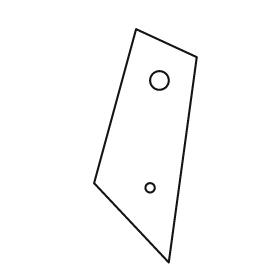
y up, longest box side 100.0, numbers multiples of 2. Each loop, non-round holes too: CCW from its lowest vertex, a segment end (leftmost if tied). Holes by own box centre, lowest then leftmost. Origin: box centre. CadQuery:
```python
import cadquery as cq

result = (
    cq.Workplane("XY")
    .moveTo(10.0, -50.0)
    .lineTo(22.0, 38.0)
    .lineTo(-4.0, 50.0)
    .lineTo(-22.0, -16.0)
    .close()
    .moveTo(2.0, -18.0)
    .circle(2.0)
    .moveTo(6.0, 28.0)
    .circle(4.0)
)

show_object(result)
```